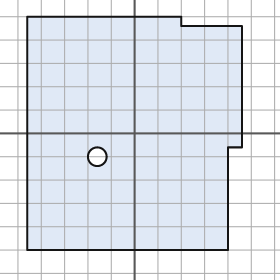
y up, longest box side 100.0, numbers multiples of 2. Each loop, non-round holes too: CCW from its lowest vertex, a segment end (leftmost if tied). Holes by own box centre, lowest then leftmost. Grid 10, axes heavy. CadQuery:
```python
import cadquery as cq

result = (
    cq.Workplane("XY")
    .moveTo(-46.0, -50.0)
    .lineTo(40.0, -50.0)
    .lineTo(40.0, -6.0)
    .lineTo(46.0, -6.0)
    .lineTo(46.0, 46.0)
    .lineTo(20.0, 46.0)
    .lineTo(20.0, 50.0)
    .lineTo(-46.0, 50.0)
    .close()
    .moveTo(-16.0, -10.0)
    .circle(4.0)
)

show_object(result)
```